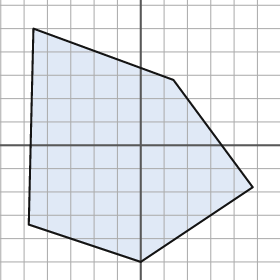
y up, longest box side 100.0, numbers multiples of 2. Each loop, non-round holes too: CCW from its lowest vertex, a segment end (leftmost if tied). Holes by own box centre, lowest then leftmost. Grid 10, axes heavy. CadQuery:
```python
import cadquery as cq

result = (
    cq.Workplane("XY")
    .moveTo(0.0, -50.0)
    .lineTo(48.0, -18.0)
    .lineTo(14.0, 28.0)
    .lineTo(-46.0, 50.0)
    .lineTo(-48.0, -34.0)
    .close()
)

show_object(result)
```